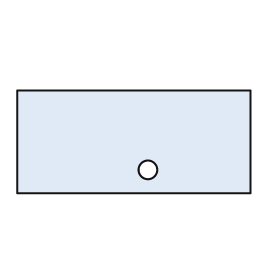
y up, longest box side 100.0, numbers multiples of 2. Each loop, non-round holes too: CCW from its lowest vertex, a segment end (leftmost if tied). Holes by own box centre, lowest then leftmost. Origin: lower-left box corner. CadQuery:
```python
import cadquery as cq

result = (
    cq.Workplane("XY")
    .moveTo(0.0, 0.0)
    .lineTo(100.0, 0.0)
    .lineTo(100.0, 44.0)
    .lineTo(0.0, 44.0)
    .close()
    .moveTo(56.0, 10.0)
    .circle(4.0)
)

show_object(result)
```